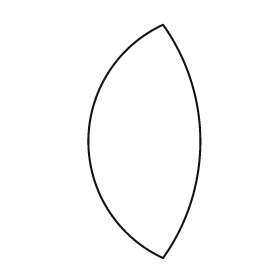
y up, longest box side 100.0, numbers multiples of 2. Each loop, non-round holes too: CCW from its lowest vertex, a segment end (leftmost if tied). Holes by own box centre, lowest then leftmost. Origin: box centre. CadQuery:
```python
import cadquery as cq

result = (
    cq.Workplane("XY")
    .moveTo(8.0, -50.0)
    .threePointArc((24.0, 0.0), (8.0, 50.0))
    .threePointArc((-24.0, 0.0), (8.0, -50.0))
    .close()
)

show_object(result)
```